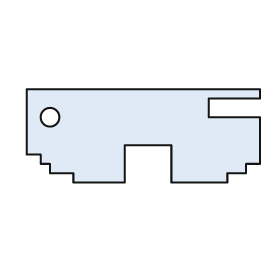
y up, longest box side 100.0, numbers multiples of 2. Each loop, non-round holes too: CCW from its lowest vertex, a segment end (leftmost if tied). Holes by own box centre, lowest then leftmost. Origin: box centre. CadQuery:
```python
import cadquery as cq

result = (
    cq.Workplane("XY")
    .moveTo(-30.0, -20.0)
    .lineTo(-8.0, -20.0)
    .lineTo(-8.0, -4.0)
    .lineTo(12.0, -4.0)
    .lineTo(12.0, -20.0)
    .lineTo(36.0, -20.0)
    .lineTo(36.0, -16.0)
    .lineTo(44.0, -16.0)
    .lineTo(44.0, -12.0)
    .lineTo(50.0, -12.0)
    .lineTo(50.0, 8.0)
    .lineTo(28.0, 8.0)
    .lineTo(28.0, 16.0)
    .lineTo(50.0, 16.0)
    .lineTo(50.0, 20.0)
    .lineTo(-50.0, 20.0)
    .lineTo(-50.0, -8.0)
    .lineTo(-44.0, -8.0)
    .lineTo(-44.0, -12.0)
    .lineTo(-40.0, -12.0)
    .lineTo(-40.0, -16.0)
    .lineTo(-30.0, -16.0)
    .close()
    .moveTo(-40.0, 8.0)
    .circle(4.0)
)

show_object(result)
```